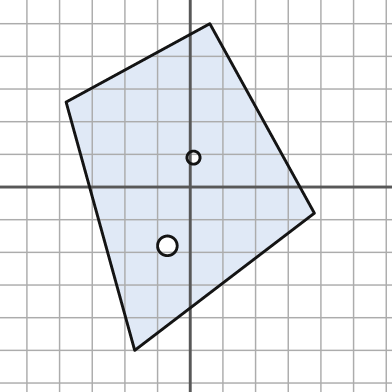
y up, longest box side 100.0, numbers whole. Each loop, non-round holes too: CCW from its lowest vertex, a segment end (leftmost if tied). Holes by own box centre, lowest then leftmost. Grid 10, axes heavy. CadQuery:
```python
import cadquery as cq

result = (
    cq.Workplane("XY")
    .moveTo(-17.0, -50.0)
    .lineTo(38.0, -8.0)
    .lineTo(6.0, 50.0)
    .lineTo(-38.0, 26.0)
    .close()
    .moveTo(-7.0, -18.0)
    .circle(3.0)
    .moveTo(1.0, 9.0)
    .circle(2.0)
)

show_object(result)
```